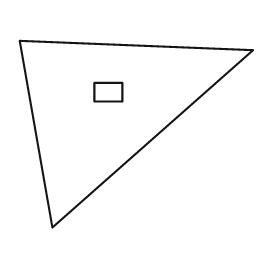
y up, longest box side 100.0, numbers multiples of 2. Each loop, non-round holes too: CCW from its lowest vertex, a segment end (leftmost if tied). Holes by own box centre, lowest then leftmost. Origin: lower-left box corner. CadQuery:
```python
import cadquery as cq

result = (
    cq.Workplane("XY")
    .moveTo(14.0, 0.0)
    .lineTo(100.0, 76.0)
    .lineTo(0.0, 80.0)
    .close()
    .moveTo(32.0, 54.0)
    .lineTo(44.0, 54.0)
    .lineTo(44.0, 62.0)
    .lineTo(32.0, 62.0)
    .close()
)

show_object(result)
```